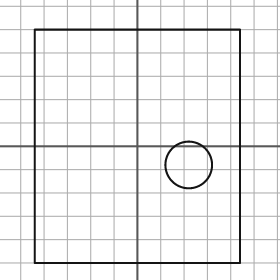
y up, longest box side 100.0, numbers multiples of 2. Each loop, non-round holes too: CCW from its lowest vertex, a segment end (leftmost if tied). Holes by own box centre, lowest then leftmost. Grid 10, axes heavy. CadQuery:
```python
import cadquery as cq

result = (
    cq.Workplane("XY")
    .moveTo(-44.0, -50.0)
    .lineTo(44.0, -50.0)
    .lineTo(44.0, 50.0)
    .lineTo(-44.0, 50.0)
    .close()
    .moveTo(22.0, -8.0)
    .circle(10.0)
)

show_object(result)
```